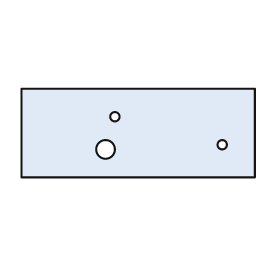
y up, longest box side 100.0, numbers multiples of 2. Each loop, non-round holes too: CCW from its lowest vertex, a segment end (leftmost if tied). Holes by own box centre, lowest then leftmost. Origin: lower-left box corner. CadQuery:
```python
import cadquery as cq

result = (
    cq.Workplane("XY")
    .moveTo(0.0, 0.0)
    .lineTo(100.0, 0.0)
    .lineTo(100.0, 38.0)
    .lineTo(0.0, 38.0)
    .close()
    .moveTo(36.0, 12.0)
    .circle(4.0)
    .moveTo(86.0, 14.0)
    .circle(2.0)
    .moveTo(40.0, 26.0)
    .circle(2.0)
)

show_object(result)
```